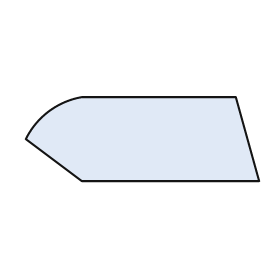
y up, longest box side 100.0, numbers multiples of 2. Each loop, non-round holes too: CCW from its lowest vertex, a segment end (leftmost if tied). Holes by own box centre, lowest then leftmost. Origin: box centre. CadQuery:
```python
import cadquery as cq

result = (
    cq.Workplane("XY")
    .moveTo(-26.0, -18.0)
    .lineTo(50.0, -18.0)
    .lineTo(40.0, 18.0)
    .lineTo(-26.0, 18.0)
    .threePointArc((-40.0, 12.0), (-50.0, 0.0))
    .close()
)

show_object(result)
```